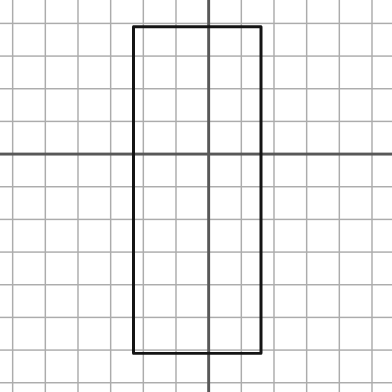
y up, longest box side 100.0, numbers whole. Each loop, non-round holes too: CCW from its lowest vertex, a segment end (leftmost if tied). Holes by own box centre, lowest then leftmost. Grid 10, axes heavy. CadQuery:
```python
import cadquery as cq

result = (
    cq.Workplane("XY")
    .moveTo(-23.0, -61.0)
    .lineTo(16.0, -61.0)
    .lineTo(16.0, 39.0)
    .lineTo(-23.0, 39.0)
    .close()
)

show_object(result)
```